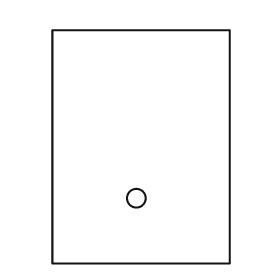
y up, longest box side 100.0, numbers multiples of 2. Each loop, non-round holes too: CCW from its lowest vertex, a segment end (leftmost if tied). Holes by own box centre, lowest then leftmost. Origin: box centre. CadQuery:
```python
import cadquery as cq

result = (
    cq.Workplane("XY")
    .moveTo(-38.0, -50.0)
    .lineTo(38.0, -50.0)
    .lineTo(38.0, 50.0)
    .lineTo(-38.0, 50.0)
    .close()
    .moveTo(-2.0, -22.0)
    .circle(4.0)
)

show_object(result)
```